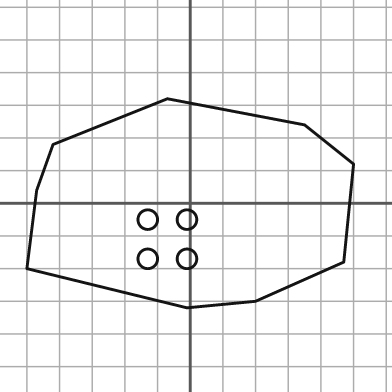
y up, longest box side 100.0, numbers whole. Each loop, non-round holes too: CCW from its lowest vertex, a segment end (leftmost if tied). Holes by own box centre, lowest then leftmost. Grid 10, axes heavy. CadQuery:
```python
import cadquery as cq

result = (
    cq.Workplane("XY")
    .moveTo(-1.0, -32.0)
    .lineTo(20.0, -30.0)
    .lineTo(47.0, -18.0)
    .lineTo(50.0, 12.0)
    .lineTo(35.0, 24.0)
    .lineTo(-7.0, 32.0)
    .lineTo(-42.0, 18.0)
    .lineTo(-47.0, 4.0)
    .lineTo(-50.0, -20.0)
    .close()
    .moveTo(-13.0, -17.0)
    .circle(3.0)
    .moveTo(-1.0, -17.0)
    .circle(3.0)
    .moveTo(-13.0, -5.0)
    .circle(3.0)
    .moveTo(-1.0, -5.0)
    .circle(3.0)
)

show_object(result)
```